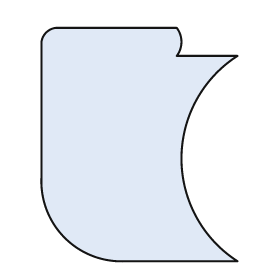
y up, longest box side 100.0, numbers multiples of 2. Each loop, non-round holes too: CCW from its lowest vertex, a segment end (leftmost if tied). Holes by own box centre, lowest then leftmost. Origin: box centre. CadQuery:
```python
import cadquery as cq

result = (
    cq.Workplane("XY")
    .moveTo(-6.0, -50.0)
    .lineTo(42.0, -50.0)
    .threePointArc((18.0, -6.0), (42.0, 38.0))
    .lineTo(16.0, 38.0)
    .threePointArc((18.0, 44.0), (16.0, 50.0))
    .lineTo(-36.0, 50.0)
    .threePointArc((-40.0, 48.0), (-42.0, 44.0))
    .lineTo(-42.0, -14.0)
    .threePointArc((-32.0, -40.0), (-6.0, -50.0))
    .close()
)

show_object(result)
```